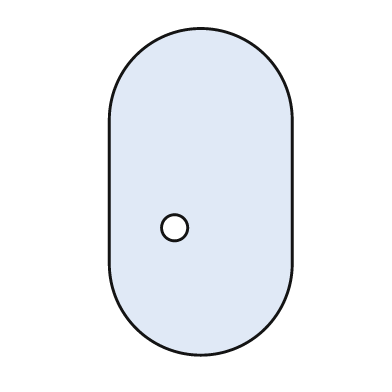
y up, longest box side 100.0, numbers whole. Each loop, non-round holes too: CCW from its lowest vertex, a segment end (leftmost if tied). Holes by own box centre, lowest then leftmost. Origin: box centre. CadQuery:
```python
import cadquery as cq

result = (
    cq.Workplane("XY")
    .moveTo(-28.0, -22.0)
    .threePointArc((0.0, -50.0), (28.0, -22.0))
    .lineTo(28.0, 22.0)
    .threePointArc((0.0, 50.0), (-28.0, 22.0))
    .close()
    .moveTo(-8.0, -11.0)
    .circle(4.0)
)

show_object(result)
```